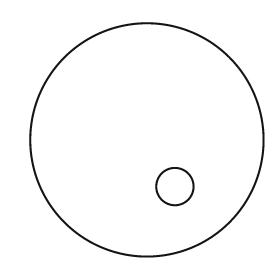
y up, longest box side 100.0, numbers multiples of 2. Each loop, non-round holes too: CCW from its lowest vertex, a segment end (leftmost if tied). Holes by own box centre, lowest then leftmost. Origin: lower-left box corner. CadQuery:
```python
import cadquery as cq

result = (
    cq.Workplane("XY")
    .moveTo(50.0, 50.0)
    .circle(50.0)
    .moveTo(62.0, 30.0)
    .circle(8.0)
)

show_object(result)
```